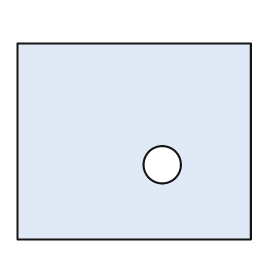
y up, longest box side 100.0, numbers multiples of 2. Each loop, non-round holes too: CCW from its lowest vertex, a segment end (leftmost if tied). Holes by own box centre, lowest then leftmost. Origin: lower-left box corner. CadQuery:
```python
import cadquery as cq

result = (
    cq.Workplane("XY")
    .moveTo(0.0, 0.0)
    .lineTo(100.0, 0.0)
    .lineTo(100.0, 84.0)
    .lineTo(0.0, 84.0)
    .close()
    .moveTo(62.0, 32.0)
    .circle(8.0)
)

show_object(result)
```